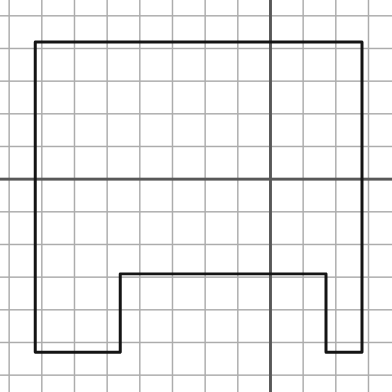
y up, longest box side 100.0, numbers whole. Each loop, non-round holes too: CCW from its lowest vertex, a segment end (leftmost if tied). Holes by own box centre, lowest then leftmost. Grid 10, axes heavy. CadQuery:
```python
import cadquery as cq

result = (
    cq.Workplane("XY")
    .moveTo(-72.0, -53.0)
    .lineTo(-46.0, -53.0)
    .lineTo(-46.0, -29.0)
    .lineTo(17.0, -29.0)
    .lineTo(17.0, -53.0)
    .lineTo(28.0, -53.0)
    .lineTo(28.0, 42.0)
    .lineTo(-72.0, 42.0)
    .close()
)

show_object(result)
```